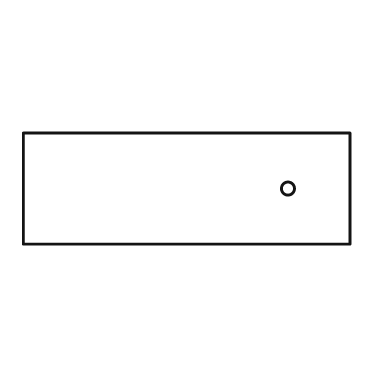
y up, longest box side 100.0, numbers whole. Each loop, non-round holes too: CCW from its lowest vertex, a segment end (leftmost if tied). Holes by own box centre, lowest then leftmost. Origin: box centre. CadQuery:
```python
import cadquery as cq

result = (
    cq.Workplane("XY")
    .moveTo(-50.0, -17.0)
    .lineTo(50.0, -17.0)
    .lineTo(50.0, 17.0)
    .lineTo(-50.0, 17.0)
    .close()
    .moveTo(31.0, 0.0)
    .circle(2.0)
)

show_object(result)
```